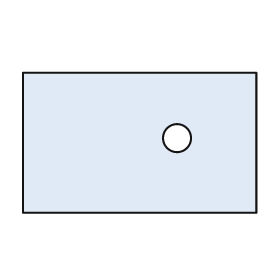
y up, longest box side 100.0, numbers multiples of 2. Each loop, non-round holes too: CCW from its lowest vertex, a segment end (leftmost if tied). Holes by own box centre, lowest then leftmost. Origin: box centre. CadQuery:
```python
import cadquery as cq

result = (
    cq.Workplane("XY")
    .moveTo(-50.0, -30.0)
    .lineTo(50.0, -30.0)
    .lineTo(50.0, 30.0)
    .lineTo(-50.0, 30.0)
    .close()
    .moveTo(16.0, 2.0)
    .circle(6.0)
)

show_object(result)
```